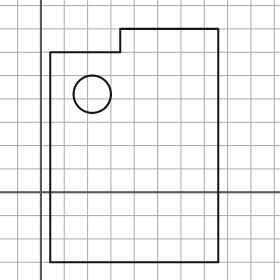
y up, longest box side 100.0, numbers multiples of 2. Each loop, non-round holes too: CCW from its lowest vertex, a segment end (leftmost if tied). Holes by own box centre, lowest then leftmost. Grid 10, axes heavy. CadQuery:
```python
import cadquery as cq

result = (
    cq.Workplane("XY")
    .moveTo(4.0, -30.0)
    .lineTo(76.0, -30.0)
    .lineTo(76.0, 70.0)
    .lineTo(34.0, 70.0)
    .lineTo(34.0, 60.0)
    .lineTo(4.0, 60.0)
    .close()
    .moveTo(22.0, 42.0)
    .circle(8.0)
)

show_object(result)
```